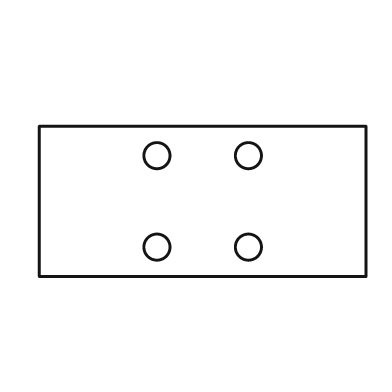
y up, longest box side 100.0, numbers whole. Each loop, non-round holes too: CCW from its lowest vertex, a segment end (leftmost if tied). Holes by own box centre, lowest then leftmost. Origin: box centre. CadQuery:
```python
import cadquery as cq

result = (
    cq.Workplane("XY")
    .moveTo(-50.0, -23.0)
    .lineTo(50.0, -23.0)
    .lineTo(50.0, 23.0)
    .lineTo(-50.0, 23.0)
    .close()
    .moveTo(-14.0, -14.0)
    .circle(4.0)
    .moveTo(14.0, -14.0)
    .circle(4.0)
    .moveTo(-14.0, 14.0)
    .circle(4.0)
    .moveTo(14.0, 14.0)
    .circle(4.0)
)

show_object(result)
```